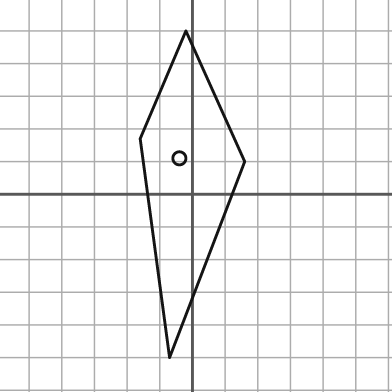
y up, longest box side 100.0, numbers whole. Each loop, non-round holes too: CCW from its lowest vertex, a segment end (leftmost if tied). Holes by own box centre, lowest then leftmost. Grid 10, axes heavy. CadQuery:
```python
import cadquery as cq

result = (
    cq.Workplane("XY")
    .moveTo(-7.0, -50.0)
    .lineTo(16.0, 10.0)
    .lineTo(-2.0, 50.0)
    .lineTo(-16.0, 17.0)
    .close()
    .moveTo(-4.0, 11.0)
    .circle(2.0)
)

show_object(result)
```